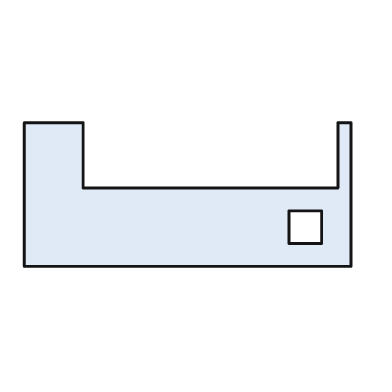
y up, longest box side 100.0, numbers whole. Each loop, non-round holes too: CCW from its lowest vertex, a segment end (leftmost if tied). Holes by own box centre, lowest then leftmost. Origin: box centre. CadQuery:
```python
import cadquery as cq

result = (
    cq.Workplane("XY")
    .moveTo(-50.0, -22.0)
    .lineTo(50.0, -22.0)
    .lineTo(50.0, 22.0)
    .lineTo(46.0, 22.0)
    .lineTo(46.0, 2.0)
    .lineTo(-32.0, 2.0)
    .lineTo(-32.0, 22.0)
    .lineTo(-50.0, 22.0)
    .close()
    .moveTo(31.0, -15.0)
    .lineTo(41.0, -15.0)
    .lineTo(41.0, -5.0)
    .lineTo(31.0, -5.0)
    .close()
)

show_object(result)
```